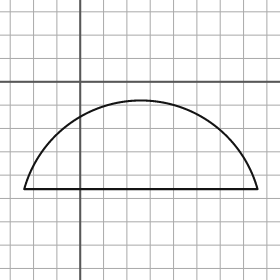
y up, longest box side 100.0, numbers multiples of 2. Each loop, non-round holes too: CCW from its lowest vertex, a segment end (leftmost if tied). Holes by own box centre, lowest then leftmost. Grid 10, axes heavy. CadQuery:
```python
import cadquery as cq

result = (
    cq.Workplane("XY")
    .moveTo(-24.0, -46.0)
    .lineTo(76.0, -46.0)
    .threePointArc((26.0, -8.0), (-24.0, -46.0))
    .close()
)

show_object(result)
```